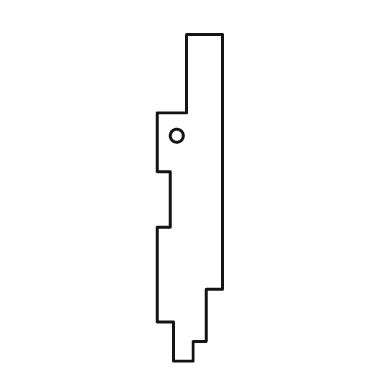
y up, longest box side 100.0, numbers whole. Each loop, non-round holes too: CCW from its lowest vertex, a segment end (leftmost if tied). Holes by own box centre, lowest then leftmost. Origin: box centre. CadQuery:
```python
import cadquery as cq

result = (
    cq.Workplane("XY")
    .moveTo(-5.0, -50.0)
    .lineTo(1.0, -50.0)
    .lineTo(1.0, -44.0)
    .lineTo(5.0, -44.0)
    .lineTo(5.0, -28.0)
    .lineTo(10.0, -28.0)
    .lineTo(10.0, 50.0)
    .lineTo(-1.0, 50.0)
    .lineTo(-1.0, 26.0)
    .lineTo(-10.0, 26.0)
    .lineTo(-10.0, 8.0)
    .lineTo(-6.0, 8.0)
    .lineTo(-6.0, -9.0)
    .lineTo(-10.0, -9.0)
    .lineTo(-10.0, -38.0)
    .lineTo(-5.0, -38.0)
    .close()
    .moveTo(-4.0, 19.0)
    .circle(2.0)
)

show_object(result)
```